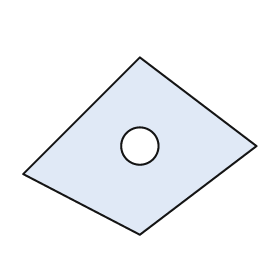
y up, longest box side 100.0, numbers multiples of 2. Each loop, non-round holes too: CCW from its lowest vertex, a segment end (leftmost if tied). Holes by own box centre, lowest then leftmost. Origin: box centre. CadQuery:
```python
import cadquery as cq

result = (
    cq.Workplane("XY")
    .moveTo(0.0, -38.0)
    .lineTo(50.0, 0.0)
    .lineTo(0.0, 38.0)
    .lineTo(-50.0, -12.0)
    .close()
    .moveTo(0.0, 0.0)
    .circle(8.0)
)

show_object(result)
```